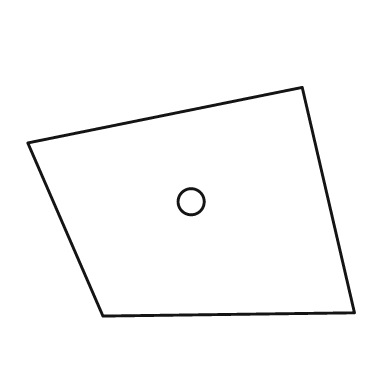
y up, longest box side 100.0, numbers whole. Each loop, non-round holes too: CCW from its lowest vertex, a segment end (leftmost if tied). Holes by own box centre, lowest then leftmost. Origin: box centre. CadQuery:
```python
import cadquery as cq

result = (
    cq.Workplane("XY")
    .moveTo(-27.0, -35.0)
    .lineTo(50.0, -34.0)
    .lineTo(34.0, 35.0)
    .lineTo(-50.0, 18.0)
    .close()
    .moveTo(0.0, 0.0)
    .circle(4.0)
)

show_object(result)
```